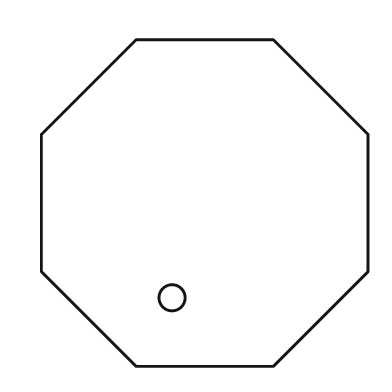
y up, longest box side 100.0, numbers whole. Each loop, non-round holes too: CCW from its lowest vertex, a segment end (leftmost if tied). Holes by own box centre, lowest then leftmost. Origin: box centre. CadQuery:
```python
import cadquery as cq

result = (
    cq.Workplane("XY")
    .moveTo(-21.0, -50.0)
    .lineTo(21.0, -50.0)
    .lineTo(50.0, -21.0)
    .lineTo(50.0, 21.0)
    .lineTo(21.0, 50.0)
    .lineTo(-21.0, 50.0)
    .lineTo(-50.0, 21.0)
    .lineTo(-50.0, -21.0)
    .close()
    .moveTo(-10.0, -29.0)
    .circle(4.0)
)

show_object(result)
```